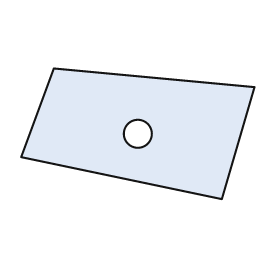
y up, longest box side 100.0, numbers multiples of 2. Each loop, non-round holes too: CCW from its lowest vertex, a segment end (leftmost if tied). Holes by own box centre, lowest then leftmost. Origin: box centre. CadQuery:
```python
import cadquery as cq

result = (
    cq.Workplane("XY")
    .moveTo(36.0, -28.0)
    .lineTo(50.0, 20.0)
    .lineTo(-36.0, 28.0)
    .lineTo(-50.0, -10.0)
    .close()
    .moveTo(0.0, 0.0)
    .circle(6.0)
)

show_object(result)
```